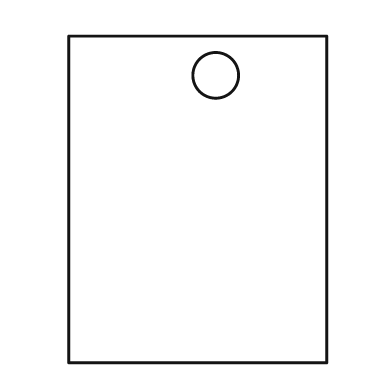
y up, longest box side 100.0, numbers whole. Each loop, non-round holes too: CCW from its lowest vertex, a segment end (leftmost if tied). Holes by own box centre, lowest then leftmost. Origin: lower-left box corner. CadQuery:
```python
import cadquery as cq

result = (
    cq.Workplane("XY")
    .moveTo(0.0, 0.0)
    .lineTo(79.0, 0.0)
    .lineTo(79.0, 100.0)
    .lineTo(0.0, 100.0)
    .close()
    .moveTo(45.0, 88.0)
    .circle(7.0)
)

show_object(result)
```